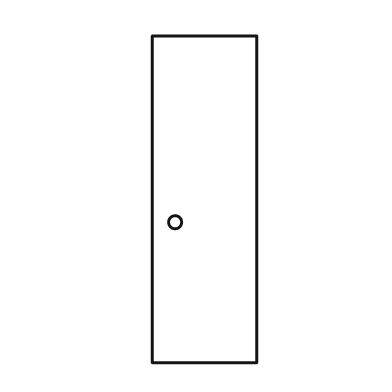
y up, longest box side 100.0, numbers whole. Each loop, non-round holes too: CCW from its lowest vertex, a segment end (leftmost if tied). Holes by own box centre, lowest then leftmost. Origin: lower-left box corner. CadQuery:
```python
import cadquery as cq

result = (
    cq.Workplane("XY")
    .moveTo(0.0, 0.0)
    .lineTo(32.0, 0.0)
    .lineTo(32.0, 100.0)
    .lineTo(0.0, 100.0)
    .close()
    .moveTo(7.0, 43.0)
    .circle(2.0)
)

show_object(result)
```